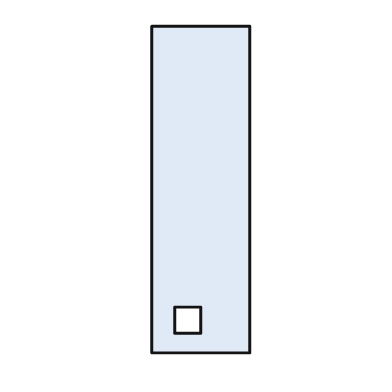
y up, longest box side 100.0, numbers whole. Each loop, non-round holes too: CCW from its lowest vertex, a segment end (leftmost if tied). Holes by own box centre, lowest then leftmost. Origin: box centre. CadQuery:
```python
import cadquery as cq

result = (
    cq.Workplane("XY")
    .moveTo(-15.0, -50.0)
    .lineTo(15.0, -50.0)
    .lineTo(15.0, 50.0)
    .lineTo(-15.0, 50.0)
    .close()
    .moveTo(-8.0, -44.0)
    .lineTo(0.0, -44.0)
    .lineTo(0.0, -36.0)
    .lineTo(-8.0, -36.0)
    .close()
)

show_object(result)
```